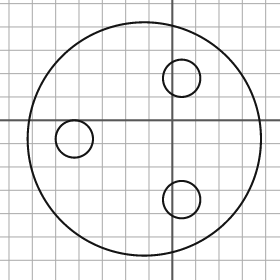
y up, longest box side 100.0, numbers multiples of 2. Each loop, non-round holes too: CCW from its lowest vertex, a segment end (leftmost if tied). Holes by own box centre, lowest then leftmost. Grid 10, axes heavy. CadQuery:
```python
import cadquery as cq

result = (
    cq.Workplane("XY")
    .moveTo(-12.0, -8.0)
    .circle(50.0)
    .moveTo(4.0, -34.0)
    .circle(8.0)
    .moveTo(-42.0, -8.0)
    .circle(8.0)
    .moveTo(4.0, 18.0)
    .circle(8.0)
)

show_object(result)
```